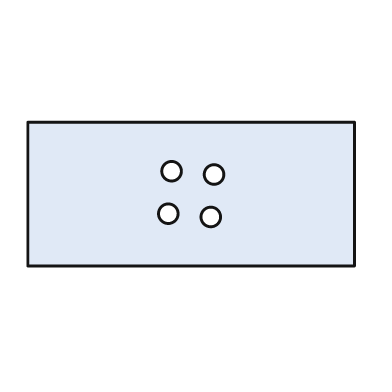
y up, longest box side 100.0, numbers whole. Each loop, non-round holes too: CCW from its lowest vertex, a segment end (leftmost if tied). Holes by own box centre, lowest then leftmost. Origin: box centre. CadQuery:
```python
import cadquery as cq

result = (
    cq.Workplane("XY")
    .moveTo(-50.0, -22.0)
    .lineTo(50.0, -22.0)
    .lineTo(50.0, 22.0)
    .lineTo(-50.0, 22.0)
    .close()
    .moveTo(6.0, -7.0)
    .circle(3.0)
    .moveTo(-7.0, -6.0)
    .circle(3.0)
    .moveTo(7.0, 6.0)
    .circle(3.0)
    .moveTo(-6.0, 7.0)
    .circle(3.0)
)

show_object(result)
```